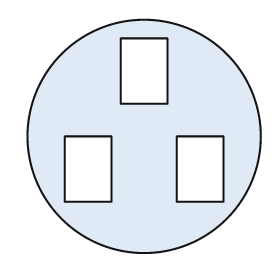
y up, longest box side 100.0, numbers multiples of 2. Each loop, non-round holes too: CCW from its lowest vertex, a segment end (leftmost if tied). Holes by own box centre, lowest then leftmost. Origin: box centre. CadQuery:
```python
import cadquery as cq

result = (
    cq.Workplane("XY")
    .moveTo(0.0, 0.0)
    .circle(50.0)
    .moveTo(-34.0, -28.0)
    .lineTo(-14.0, -28.0)
    .lineTo(-14.0, 0.0)
    .lineTo(-34.0, 0.0)
    .close()
    .moveTo(14.0, -28.0)
    .lineTo(34.0, -28.0)
    .lineTo(34.0, 0.0)
    .lineTo(14.0, 0.0)
    .close()
    .moveTo(-10.0, 14.0)
    .lineTo(10.0, 14.0)
    .lineTo(10.0, 42.0)
    .lineTo(-10.0, 42.0)
    .close()
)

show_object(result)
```